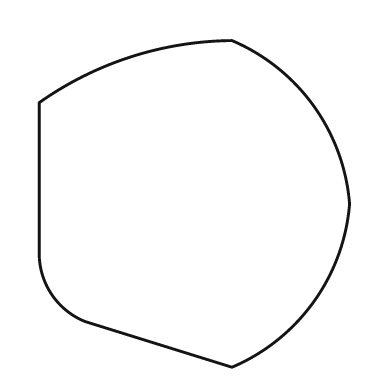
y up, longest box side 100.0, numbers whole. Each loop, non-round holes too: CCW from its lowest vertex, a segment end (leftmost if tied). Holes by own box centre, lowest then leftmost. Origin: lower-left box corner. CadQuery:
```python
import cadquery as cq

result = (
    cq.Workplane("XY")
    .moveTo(59.0, 0.0)
    .threePointArc((84.0, 20.0), (95.0, 50.0))
    .threePointArc((84.0, 80.0), (59.0, 100.0))
    .threePointArc((28.0, 95.0), (0.0, 81.0))
    .lineTo(0.0, 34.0)
    .threePointArc((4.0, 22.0), (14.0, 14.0))
    .close()
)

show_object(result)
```